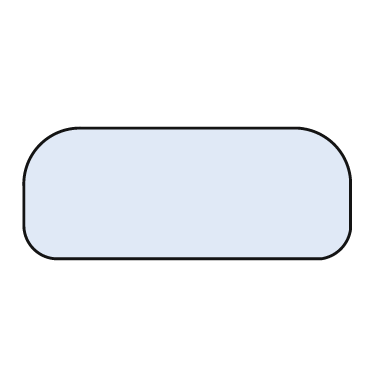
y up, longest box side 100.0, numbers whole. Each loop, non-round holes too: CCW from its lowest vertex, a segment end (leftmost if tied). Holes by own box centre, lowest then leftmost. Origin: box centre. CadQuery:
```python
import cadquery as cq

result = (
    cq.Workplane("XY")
    .moveTo(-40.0, -20.0)
    .lineTo(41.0, -20.0)
    .threePointArc((47.0, -17.0), (50.0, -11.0))
    .lineTo(50.0, 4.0)
    .threePointArc((45.0, 15.0), (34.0, 20.0))
    .lineTo(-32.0, 20.0)
    .threePointArc((-45.0, 15.0), (-50.0, 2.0))
    .lineTo(-50.0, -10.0)
    .threePointArc((-47.0, -17.0), (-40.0, -20.0))
    .close()
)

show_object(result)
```